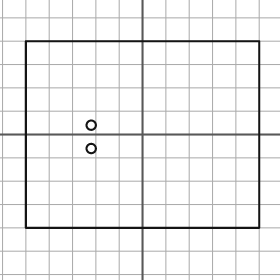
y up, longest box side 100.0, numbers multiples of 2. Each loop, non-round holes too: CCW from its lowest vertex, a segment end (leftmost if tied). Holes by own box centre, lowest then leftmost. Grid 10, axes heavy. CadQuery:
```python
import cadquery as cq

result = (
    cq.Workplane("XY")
    .moveTo(-50.0, -40.0)
    .lineTo(50.0, -40.0)
    .lineTo(50.0, 40.0)
    .lineTo(-50.0, 40.0)
    .close()
    .moveTo(-22.0, -6.0)
    .circle(2.0)
    .moveTo(-22.0, 4.0)
    .circle(2.0)
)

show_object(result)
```